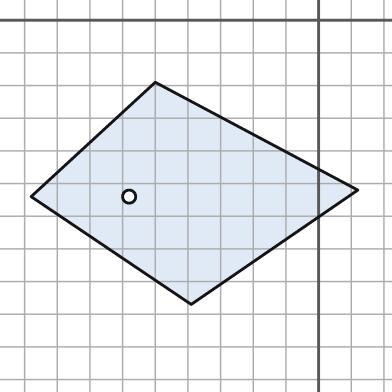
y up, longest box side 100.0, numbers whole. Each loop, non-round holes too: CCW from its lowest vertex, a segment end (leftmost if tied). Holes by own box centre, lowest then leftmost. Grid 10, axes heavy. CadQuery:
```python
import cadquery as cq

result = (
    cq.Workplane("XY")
    .moveTo(-39.0, -87.0)
    .lineTo(12.0, -52.0)
    .lineTo(-50.0, -19.0)
    .lineTo(-88.0, -54.0)
    .close()
    .moveTo(-58.0, -54.0)
    .circle(2.0)
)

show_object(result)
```